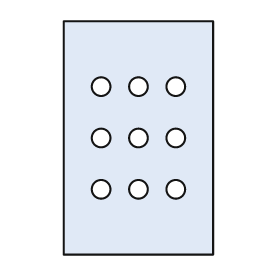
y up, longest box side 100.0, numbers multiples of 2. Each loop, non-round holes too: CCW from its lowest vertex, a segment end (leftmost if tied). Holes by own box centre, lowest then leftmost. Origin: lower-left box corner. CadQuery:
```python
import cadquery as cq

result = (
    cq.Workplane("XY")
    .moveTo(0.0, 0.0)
    .lineTo(64.0, 0.0)
    .lineTo(64.0, 100.0)
    .lineTo(0.0, 100.0)
    .close()
    .moveTo(16.0, 28.0)
    .circle(4.0)
    .moveTo(32.0, 28.0)
    .circle(4.0)
    .moveTo(48.0, 28.0)
    .circle(4.0)
    .moveTo(16.0, 50.0)
    .circle(4.0)
    .moveTo(32.0, 50.0)
    .circle(4.0)
    .moveTo(48.0, 50.0)
    .circle(4.0)
    .moveTo(16.0, 72.0)
    .circle(4.0)
    .moveTo(32.0, 72.0)
    .circle(4.0)
    .moveTo(48.0, 72.0)
    .circle(4.0)
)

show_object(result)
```